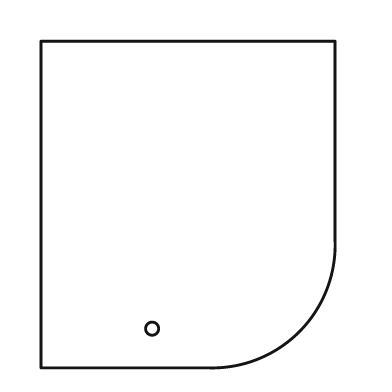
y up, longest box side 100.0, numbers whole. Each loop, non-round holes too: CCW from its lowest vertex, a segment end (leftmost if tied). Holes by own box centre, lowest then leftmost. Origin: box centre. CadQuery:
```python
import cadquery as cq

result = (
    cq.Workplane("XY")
    .moveTo(-45.0, -50.0)
    .lineTo(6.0, -50.0)
    .threePointArc((34.0, -39.0), (45.0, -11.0))
    .lineTo(45.0, 50.0)
    .lineTo(-45.0, 50.0)
    .close()
    .moveTo(-11.0, -38.0)
    .circle(2.0)
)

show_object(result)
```